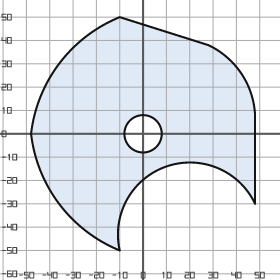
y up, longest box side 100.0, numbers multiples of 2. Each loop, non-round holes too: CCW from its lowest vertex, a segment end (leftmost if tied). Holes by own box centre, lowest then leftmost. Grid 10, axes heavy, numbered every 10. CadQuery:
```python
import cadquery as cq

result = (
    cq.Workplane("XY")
    .moveTo(-10.0, -50.0)
    .threePointArc((10.0, -14.0), (48.0, -30.0))
    .lineTo(48.0, 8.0)
    .threePointArc((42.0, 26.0), (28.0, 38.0))
    .lineTo(-10.0, 50.0)
    .threePointArc((-36.0, 30.0), (-48.0, 0.0))
    .threePointArc((-36.0, -30.0), (-10.0, -50.0))
    .close()
    .moveTo(0.0, 0.0)
    .circle(8.0)
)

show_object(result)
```